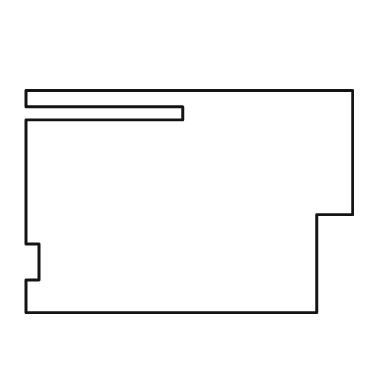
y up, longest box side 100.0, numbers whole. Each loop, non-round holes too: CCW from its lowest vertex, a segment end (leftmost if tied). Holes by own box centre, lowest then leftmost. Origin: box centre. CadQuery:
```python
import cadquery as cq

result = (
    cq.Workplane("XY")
    .moveTo(-50.0, -34.0)
    .lineTo(39.0, -34.0)
    .lineTo(39.0, -4.0)
    .lineTo(50.0, -4.0)
    .lineTo(50.0, 34.0)
    .lineTo(-50.0, 34.0)
    .lineTo(-50.0, 29.0)
    .lineTo(-2.0, 29.0)
    .lineTo(-2.0, 25.0)
    .lineTo(-50.0, 25.0)
    .lineTo(-50.0, -13.0)
    .lineTo(-46.0, -13.0)
    .lineTo(-46.0, -24.0)
    .lineTo(-50.0, -24.0)
    .close()
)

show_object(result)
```